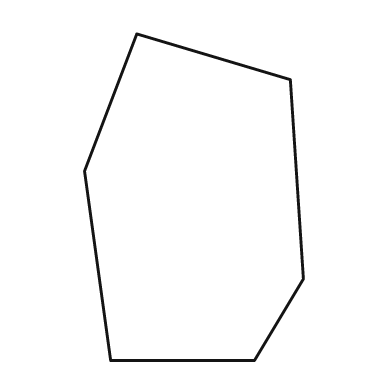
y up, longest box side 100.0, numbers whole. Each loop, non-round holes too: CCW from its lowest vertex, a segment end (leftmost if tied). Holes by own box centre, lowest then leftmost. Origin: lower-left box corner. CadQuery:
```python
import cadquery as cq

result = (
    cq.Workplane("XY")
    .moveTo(8.0, 0.0)
    .lineTo(52.0, 0.0)
    .lineTo(67.0, 25.0)
    .lineTo(63.0, 86.0)
    .lineTo(16.0, 100.0)
    .lineTo(0.0, 58.0)
    .close()
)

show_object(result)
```